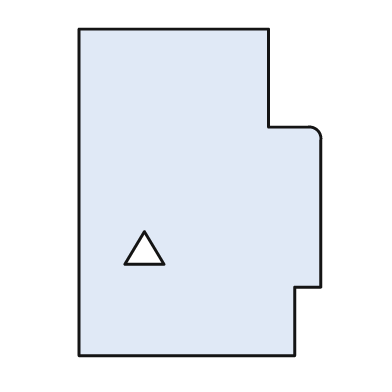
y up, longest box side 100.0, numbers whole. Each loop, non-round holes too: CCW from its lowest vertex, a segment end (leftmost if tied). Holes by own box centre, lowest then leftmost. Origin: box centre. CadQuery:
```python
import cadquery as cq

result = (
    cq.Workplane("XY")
    .moveTo(-37.0, -50.0)
    .lineTo(29.0, -50.0)
    .lineTo(29.0, -29.0)
    .lineTo(37.0, -29.0)
    .lineTo(37.0, 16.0)
    .threePointArc((36.0, 19.0), (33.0, 20.0))
    .lineTo(21.0, 20.0)
    .lineTo(21.0, 50.0)
    .lineTo(-37.0, 50.0)
    .close()
    .moveTo(-23.0, -22.0)
    .lineTo(-11.0, -22.0)
    .lineTo(-17.0, -12.0)
    .close()
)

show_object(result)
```